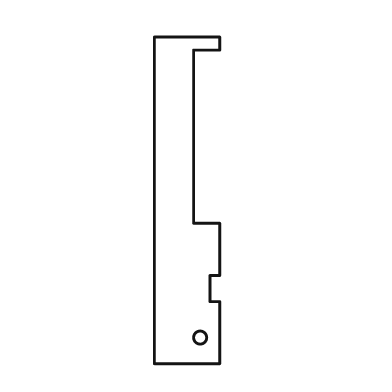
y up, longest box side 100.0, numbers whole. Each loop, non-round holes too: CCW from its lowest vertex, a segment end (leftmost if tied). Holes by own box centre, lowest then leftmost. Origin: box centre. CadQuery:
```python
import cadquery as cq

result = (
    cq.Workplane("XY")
    .moveTo(-10.0, -50.0)
    .lineTo(10.0, -50.0)
    .lineTo(10.0, -31.0)
    .lineTo(7.0, -31.0)
    .lineTo(7.0, -23.0)
    .lineTo(10.0, -23.0)
    .lineTo(10.0, -7.0)
    .lineTo(2.0, -7.0)
    .lineTo(2.0, 46.0)
    .lineTo(10.0, 46.0)
    .lineTo(10.0, 50.0)
    .lineTo(-10.0, 50.0)
    .close()
    .moveTo(4.0, -42.0)
    .circle(2.0)
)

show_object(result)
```